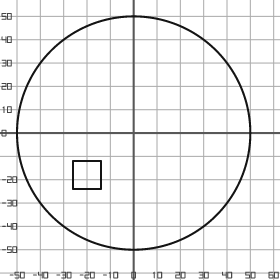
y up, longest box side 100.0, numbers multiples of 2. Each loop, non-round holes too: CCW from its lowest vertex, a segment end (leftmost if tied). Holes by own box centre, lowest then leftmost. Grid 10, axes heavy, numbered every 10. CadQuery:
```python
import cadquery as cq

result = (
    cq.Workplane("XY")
    .moveTo(0.0, 0.0)
    .circle(50.0)
    .moveTo(-26.0, -24.0)
    .lineTo(-14.0, -24.0)
    .lineTo(-14.0, -12.0)
    .lineTo(-26.0, -12.0)
    .close()
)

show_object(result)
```